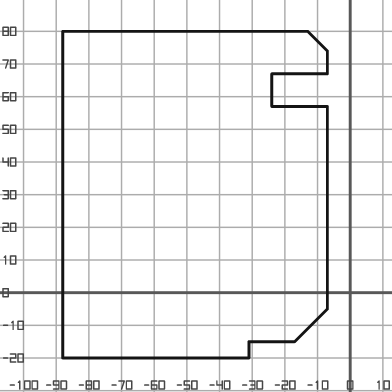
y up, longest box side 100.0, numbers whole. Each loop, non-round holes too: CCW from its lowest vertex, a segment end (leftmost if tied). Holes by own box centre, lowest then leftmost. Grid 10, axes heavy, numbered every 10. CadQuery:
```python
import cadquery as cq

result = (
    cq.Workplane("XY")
    .moveTo(-88.0, -20.0)
    .lineTo(-31.0, -20.0)
    .lineTo(-31.0, -15.0)
    .lineTo(-17.0, -15.0)
    .lineTo(-7.0, -5.0)
    .lineTo(-7.0, 57.0)
    .lineTo(-24.0, 57.0)
    .lineTo(-24.0, 67.0)
    .lineTo(-7.0, 67.0)
    .lineTo(-7.0, 74.0)
    .lineTo(-13.0, 80.0)
    .lineTo(-88.0, 80.0)
    .close()
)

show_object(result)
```